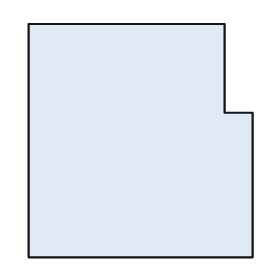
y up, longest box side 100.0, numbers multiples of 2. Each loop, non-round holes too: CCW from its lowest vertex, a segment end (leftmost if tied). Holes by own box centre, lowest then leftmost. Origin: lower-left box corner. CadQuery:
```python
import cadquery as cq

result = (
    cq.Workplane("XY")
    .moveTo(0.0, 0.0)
    .lineTo(96.0, 0.0)
    .lineTo(96.0, 62.0)
    .lineTo(84.0, 62.0)
    .lineTo(84.0, 100.0)
    .lineTo(0.0, 100.0)
    .close()
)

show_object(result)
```